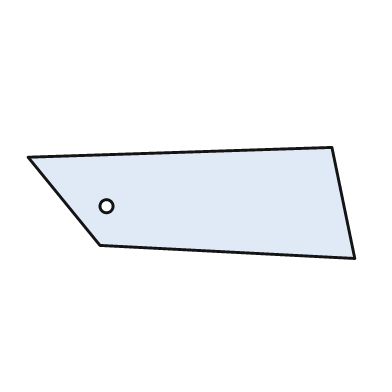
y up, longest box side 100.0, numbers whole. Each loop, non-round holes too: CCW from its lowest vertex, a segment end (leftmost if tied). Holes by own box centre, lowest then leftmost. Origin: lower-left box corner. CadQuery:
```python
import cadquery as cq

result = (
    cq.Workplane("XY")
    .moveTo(100.0, 0.0)
    .lineTo(93.0, 34.0)
    .lineTo(0.0, 31.0)
    .lineTo(22.0, 4.0)
    .close()
    .moveTo(24.0, 16.0)
    .circle(2.0)
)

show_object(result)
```